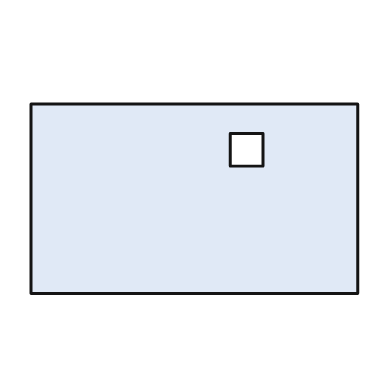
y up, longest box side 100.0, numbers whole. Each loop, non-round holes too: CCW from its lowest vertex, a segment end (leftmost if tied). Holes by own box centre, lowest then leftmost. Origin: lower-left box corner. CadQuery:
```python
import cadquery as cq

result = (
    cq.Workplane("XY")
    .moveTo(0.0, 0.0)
    .lineTo(100.0, 0.0)
    .lineTo(100.0, 58.0)
    .lineTo(0.0, 58.0)
    .close()
    .moveTo(61.0, 39.0)
    .lineTo(71.0, 39.0)
    .lineTo(71.0, 49.0)
    .lineTo(61.0, 49.0)
    .close()
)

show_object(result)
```